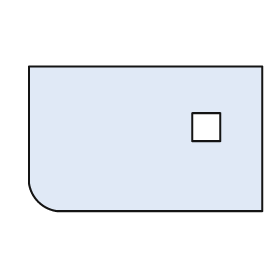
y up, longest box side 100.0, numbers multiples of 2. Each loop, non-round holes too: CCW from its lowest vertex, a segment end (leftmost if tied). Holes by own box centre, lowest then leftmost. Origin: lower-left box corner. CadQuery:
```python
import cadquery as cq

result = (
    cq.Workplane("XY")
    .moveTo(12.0, 0.0)
    .lineTo(100.0, 0.0)
    .lineTo(100.0, 62.0)
    .lineTo(0.0, 62.0)
    .lineTo(0.0, 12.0)
    .threePointArc((4.0, 4.0), (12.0, 0.0))
    .close()
    .moveTo(70.0, 30.0)
    .lineTo(82.0, 30.0)
    .lineTo(82.0, 42.0)
    .lineTo(70.0, 42.0)
    .close()
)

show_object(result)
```